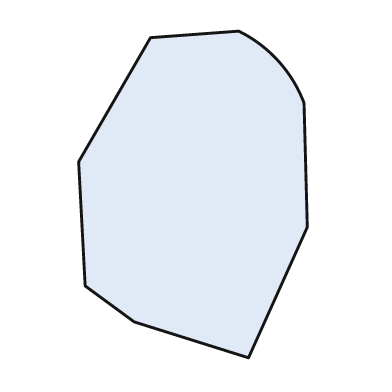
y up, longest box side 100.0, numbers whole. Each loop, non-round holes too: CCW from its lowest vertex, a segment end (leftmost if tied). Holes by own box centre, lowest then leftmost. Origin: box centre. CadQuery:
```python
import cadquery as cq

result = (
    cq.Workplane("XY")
    .moveTo(17.0, -50.0)
    .lineTo(35.0, -10.0)
    .lineTo(34.0, 28.0)
    .threePointArc((26.0, 41.0), (14.0, 50.0))
    .lineTo(-13.0, 48.0)
    .lineTo(-35.0, 10.0)
    .lineTo(-33.0, -28.0)
    .lineTo(-18.0, -39.0)
    .close()
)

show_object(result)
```